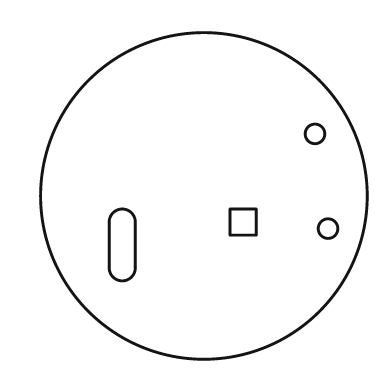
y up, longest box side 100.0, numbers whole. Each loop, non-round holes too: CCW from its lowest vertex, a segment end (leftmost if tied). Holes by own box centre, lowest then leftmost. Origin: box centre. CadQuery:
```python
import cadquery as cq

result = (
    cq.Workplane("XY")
    .moveTo(0.0, 0.0)
    .circle(50.0)
    .moveTo(-29.0, -22.0)
    .threePointArc((-25.0, -26.0), (-21.0, -22.0))
    .lineTo(-21.0, -8.0)
    .threePointArc((-25.0, -4.0), (-29.0, -8.0))
    .close()
    .moveTo(38.0, -10.0)
    .circle(3.0)
    .moveTo(8.0, -12.0)
    .lineTo(16.0, -12.0)
    .lineTo(16.0, -4.0)
    .lineTo(8.0, -4.0)
    .close()
    .moveTo(34.0, 19.0)
    .circle(3.0)
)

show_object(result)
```